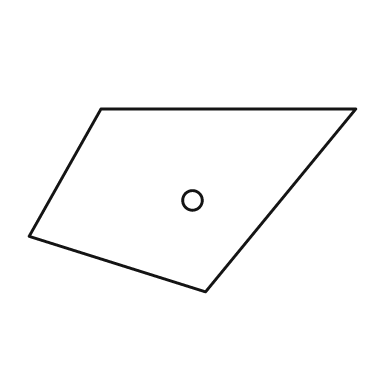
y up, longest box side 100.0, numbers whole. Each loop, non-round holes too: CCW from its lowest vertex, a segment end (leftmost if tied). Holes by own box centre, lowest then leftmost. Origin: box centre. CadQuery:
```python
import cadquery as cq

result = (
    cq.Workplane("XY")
    .moveTo(4.0, -28.0)
    .lineTo(50.0, 28.0)
    .lineTo(-28.0, 28.0)
    .lineTo(-50.0, -11.0)
    .close()
    .moveTo(0.0, 0.0)
    .circle(3.0)
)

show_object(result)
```